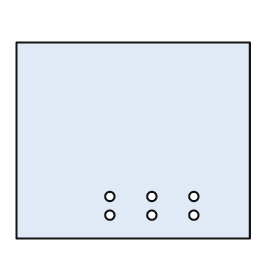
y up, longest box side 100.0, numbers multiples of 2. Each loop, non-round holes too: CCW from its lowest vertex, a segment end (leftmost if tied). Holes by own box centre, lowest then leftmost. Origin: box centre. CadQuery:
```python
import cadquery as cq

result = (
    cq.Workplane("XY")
    .moveTo(-50.0, -42.0)
    .lineTo(50.0, -42.0)
    .lineTo(50.0, 42.0)
    .lineTo(-50.0, 42.0)
    .close()
    .moveTo(-10.0, -32.0)
    .circle(2.0)
    .moveTo(8.0, -32.0)
    .circle(2.0)
    .moveTo(26.0, -32.0)
    .circle(2.0)
    .moveTo(-10.0, -24.0)
    .circle(2.0)
    .moveTo(8.0, -24.0)
    .circle(2.0)
    .moveTo(26.0, -24.0)
    .circle(2.0)
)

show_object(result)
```